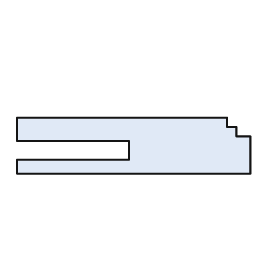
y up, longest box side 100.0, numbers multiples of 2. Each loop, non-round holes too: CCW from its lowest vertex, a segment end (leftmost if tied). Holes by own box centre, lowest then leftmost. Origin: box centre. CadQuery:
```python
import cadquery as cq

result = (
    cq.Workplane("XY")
    .moveTo(-50.0, -12.0)
    .lineTo(50.0, -12.0)
    .lineTo(50.0, 4.0)
    .lineTo(44.0, 4.0)
    .lineTo(44.0, 8.0)
    .lineTo(40.0, 8.0)
    .lineTo(40.0, 12.0)
    .lineTo(-50.0, 12.0)
    .lineTo(-50.0, 2.0)
    .lineTo(-2.0, 2.0)
    .lineTo(-2.0, -6.0)
    .lineTo(-50.0, -6.0)
    .close()
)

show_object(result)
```